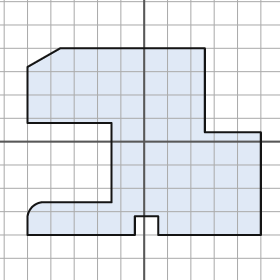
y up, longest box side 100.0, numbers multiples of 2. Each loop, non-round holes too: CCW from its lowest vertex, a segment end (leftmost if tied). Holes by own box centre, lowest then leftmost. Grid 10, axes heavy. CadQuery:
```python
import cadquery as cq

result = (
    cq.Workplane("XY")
    .moveTo(-50.0, -40.0)
    .lineTo(-4.0, -40.0)
    .lineTo(-4.0, -32.0)
    .lineTo(6.0, -32.0)
    .lineTo(6.0, -40.0)
    .lineTo(50.0, -40.0)
    .lineTo(50.0, 4.0)
    .lineTo(26.0, 4.0)
    .lineTo(26.0, 40.0)
    .lineTo(-36.0, 40.0)
    .lineTo(-50.0, 32.0)
    .lineTo(-50.0, 8.0)
    .lineTo(-14.0, 8.0)
    .lineTo(-14.0, -26.0)
    .lineTo(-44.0, -26.0)
    .threePointArc((-48.0, -28.0), (-50.0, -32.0))
    .close()
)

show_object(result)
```